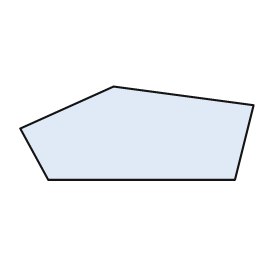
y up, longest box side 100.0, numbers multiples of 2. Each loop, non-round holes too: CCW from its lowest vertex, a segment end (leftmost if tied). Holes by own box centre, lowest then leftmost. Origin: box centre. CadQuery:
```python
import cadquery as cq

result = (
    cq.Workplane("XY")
    .moveTo(-38.0, -20.0)
    .lineTo(42.0, -20.0)
    .lineTo(50.0, 12.0)
    .lineTo(-10.0, 20.0)
    .lineTo(-50.0, 2.0)
    .close()
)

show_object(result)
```